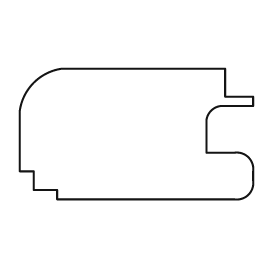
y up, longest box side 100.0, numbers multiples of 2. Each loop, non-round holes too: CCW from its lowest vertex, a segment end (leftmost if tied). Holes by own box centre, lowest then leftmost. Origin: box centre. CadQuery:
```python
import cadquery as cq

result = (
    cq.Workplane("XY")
    .moveTo(-34.0, -28.0)
    .lineTo(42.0, -28.0)
    .threePointArc((48.0, -26.0), (50.0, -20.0))
    .lineTo(50.0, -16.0)
    .threePointArc((48.0, -10.0), (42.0, -8.0))
    .lineTo(30.0, -8.0)
    .lineTo(30.0, 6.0)
    .threePointArc((32.0, 10.0), (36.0, 12.0))
    .lineTo(50.0, 12.0)
    .lineTo(50.0, 16.0)
    .lineTo(38.0, 16.0)
    .lineTo(38.0, 28.0)
    .lineTo(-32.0, 28.0)
    .threePointArc((-44.0, 22.0), (-50.0, 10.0))
    .lineTo(-50.0, -16.0)
    .lineTo(-44.0, -16.0)
    .lineTo(-44.0, -24.0)
    .lineTo(-34.0, -24.0)
    .close()
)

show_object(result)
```